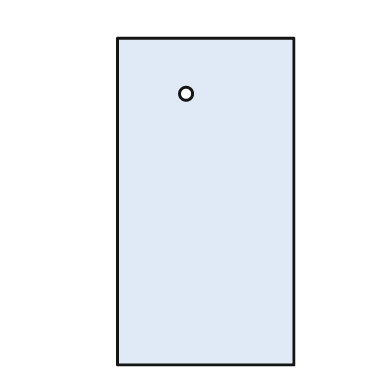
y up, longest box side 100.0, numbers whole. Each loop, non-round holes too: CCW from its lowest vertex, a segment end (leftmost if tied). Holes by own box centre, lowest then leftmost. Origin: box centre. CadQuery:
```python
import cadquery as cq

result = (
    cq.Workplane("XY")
    .moveTo(-27.0, -50.0)
    .lineTo(27.0, -50.0)
    .lineTo(27.0, 50.0)
    .lineTo(-27.0, 50.0)
    .close()
    .moveTo(-6.0, 33.0)
    .circle(2.0)
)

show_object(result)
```